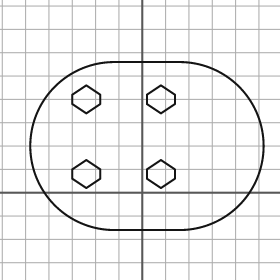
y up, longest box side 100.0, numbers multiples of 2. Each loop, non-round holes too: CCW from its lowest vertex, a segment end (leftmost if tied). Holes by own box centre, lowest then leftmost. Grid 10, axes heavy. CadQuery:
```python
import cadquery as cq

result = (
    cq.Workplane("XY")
    .moveTo(-12.0, -16.0)
    .lineTo(16.0, -16.0)
    .threePointArc((52.0, 20.0), (16.0, 56.0))
    .lineTo(-12.0, 56.0)
    .threePointArc((-48.0, 20.0), (-12.0, -16.0))
    .close()
    .moveTo(-24.0, 2.0)
    .lineTo(-18.0, 6.0)
    .lineTo(-18.0, 10.0)
    .lineTo(-24.0, 14.0)
    .lineTo(-30.0, 10.0)
    .lineTo(-30.0, 6.0)
    .close()
    .moveTo(8.0, 2.0)
    .lineTo(14.0, 6.0)
    .lineTo(14.0, 10.0)
    .lineTo(8.0, 14.0)
    .lineTo(2.0, 10.0)
    .lineTo(2.0, 6.0)
    .close()
    .moveTo(-24.0, 34.0)
    .lineTo(-18.0, 38.0)
    .lineTo(-18.0, 42.0)
    .lineTo(-24.0, 46.0)
    .lineTo(-30.0, 42.0)
    .lineTo(-30.0, 38.0)
    .close()
    .moveTo(8.0, 34.0)
    .lineTo(14.0, 38.0)
    .lineTo(14.0, 42.0)
    .lineTo(8.0, 46.0)
    .lineTo(2.0, 42.0)
    .lineTo(2.0, 38.0)
    .close()
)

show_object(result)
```